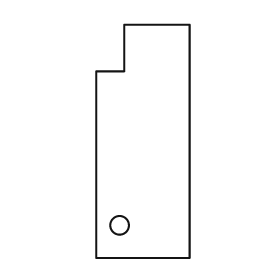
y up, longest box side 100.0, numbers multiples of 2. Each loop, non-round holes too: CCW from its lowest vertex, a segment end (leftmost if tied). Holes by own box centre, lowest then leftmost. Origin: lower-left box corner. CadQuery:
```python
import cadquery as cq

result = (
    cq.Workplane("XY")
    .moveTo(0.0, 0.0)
    .lineTo(40.0, 0.0)
    .lineTo(40.0, 100.0)
    .lineTo(12.0, 100.0)
    .lineTo(12.0, 80.0)
    .lineTo(0.0, 80.0)
    .close()
    .moveTo(10.0, 14.0)
    .circle(4.0)
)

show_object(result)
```